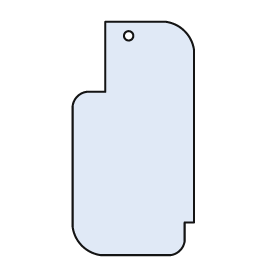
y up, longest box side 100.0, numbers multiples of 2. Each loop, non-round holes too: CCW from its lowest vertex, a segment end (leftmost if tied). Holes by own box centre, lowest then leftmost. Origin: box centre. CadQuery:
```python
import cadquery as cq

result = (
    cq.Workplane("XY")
    .moveTo(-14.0, -50.0)
    .lineTo(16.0, -50.0)
    .threePointArc((20.0, -48.0), (22.0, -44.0))
    .lineTo(22.0, -36.0)
    .lineTo(26.0, -36.0)
    .lineTo(26.0, 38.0)
    .threePointArc((22.0, 46.0), (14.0, 50.0))
    .lineTo(-12.0, 50.0)
    .lineTo(-12.0, 20.0)
    .lineTo(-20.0, 20.0)
    .threePointArc((-24.0, 18.0), (-26.0, 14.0))
    .lineTo(-26.0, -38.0)
    .threePointArc((-22.0, -46.0), (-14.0, -50.0))
    .close()
    .moveTo(-2.0, 44.0)
    .circle(2.0)
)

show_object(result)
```